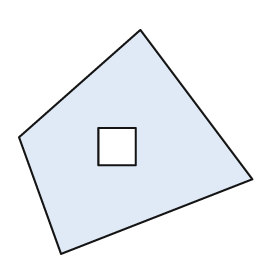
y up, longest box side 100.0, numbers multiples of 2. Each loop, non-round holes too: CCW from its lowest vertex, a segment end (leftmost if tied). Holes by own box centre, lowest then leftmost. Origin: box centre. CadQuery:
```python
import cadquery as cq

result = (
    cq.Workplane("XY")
    .moveTo(-32.0, -48.0)
    .lineTo(50.0, -16.0)
    .lineTo(2.0, 48.0)
    .lineTo(-50.0, 2.0)
    .close()
    .moveTo(-16.0, -10.0)
    .lineTo(0.0, -10.0)
    .lineTo(0.0, 6.0)
    .lineTo(-16.0, 6.0)
    .close()
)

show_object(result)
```